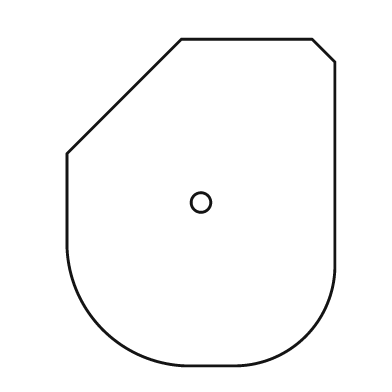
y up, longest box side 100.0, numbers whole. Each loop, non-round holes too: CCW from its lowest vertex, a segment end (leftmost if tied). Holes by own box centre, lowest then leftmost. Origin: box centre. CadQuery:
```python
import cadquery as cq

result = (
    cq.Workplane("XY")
    .moveTo(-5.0, -50.0)
    .lineTo(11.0, -50.0)
    .threePointArc((32.0, -41.0), (41.0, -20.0))
    .lineTo(41.0, 43.0)
    .lineTo(34.0, 50.0)
    .lineTo(-6.0, 50.0)
    .lineTo(-41.0, 15.0)
    .lineTo(-41.0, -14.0)
    .threePointArc((-30.0, -39.0), (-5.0, -50.0))
    .close()
    .moveTo(0.0, 0.0)
    .circle(3.0)
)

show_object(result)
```